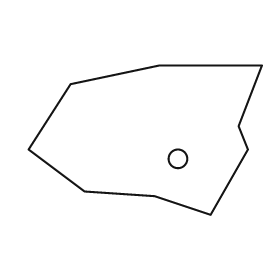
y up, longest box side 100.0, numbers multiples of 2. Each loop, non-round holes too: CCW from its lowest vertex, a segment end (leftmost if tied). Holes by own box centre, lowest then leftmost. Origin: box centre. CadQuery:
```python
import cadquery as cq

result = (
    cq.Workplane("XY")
    .moveTo(28.0, -32.0)
    .lineTo(44.0, -4.0)
    .lineTo(40.0, 6.0)
    .lineTo(50.0, 32.0)
    .lineTo(6.0, 32.0)
    .lineTo(-32.0, 24.0)
    .lineTo(-50.0, -4.0)
    .lineTo(-26.0, -22.0)
    .lineTo(4.0, -24.0)
    .close()
    .moveTo(14.0, -8.0)
    .circle(4.0)
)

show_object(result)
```